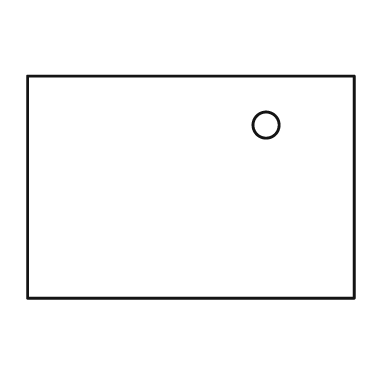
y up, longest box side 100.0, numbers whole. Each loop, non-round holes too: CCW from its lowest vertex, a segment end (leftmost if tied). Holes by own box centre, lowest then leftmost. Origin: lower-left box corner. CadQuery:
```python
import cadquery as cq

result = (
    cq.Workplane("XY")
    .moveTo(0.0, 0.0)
    .lineTo(100.0, 0.0)
    .lineTo(100.0, 68.0)
    .lineTo(0.0, 68.0)
    .close()
    .moveTo(73.0, 53.0)
    .circle(4.0)
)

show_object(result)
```